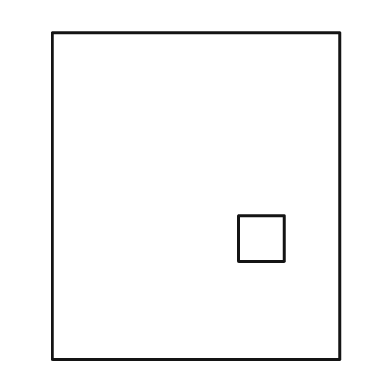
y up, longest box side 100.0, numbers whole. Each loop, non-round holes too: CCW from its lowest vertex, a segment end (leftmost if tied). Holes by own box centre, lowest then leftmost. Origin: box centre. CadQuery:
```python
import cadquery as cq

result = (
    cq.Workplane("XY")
    .moveTo(-44.0, -50.0)
    .lineTo(44.0, -50.0)
    .lineTo(44.0, 50.0)
    .lineTo(-44.0, 50.0)
    .close()
    .moveTo(13.0, -20.0)
    .lineTo(27.0, -20.0)
    .lineTo(27.0, -6.0)
    .lineTo(13.0, -6.0)
    .close()
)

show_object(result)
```